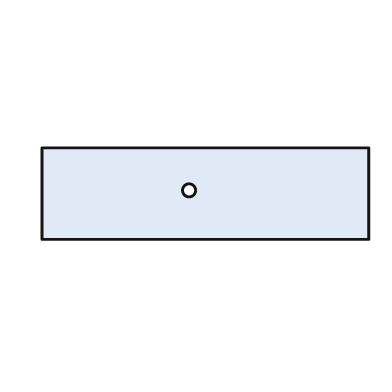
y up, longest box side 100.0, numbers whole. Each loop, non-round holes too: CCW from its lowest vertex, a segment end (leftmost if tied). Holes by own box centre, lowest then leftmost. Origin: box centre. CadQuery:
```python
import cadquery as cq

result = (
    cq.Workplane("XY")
    .moveTo(-50.0, -14.0)
    .lineTo(50.0, -14.0)
    .lineTo(50.0, 14.0)
    .lineTo(-50.0, 14.0)
    .close()
    .moveTo(-5.0, 1.0)
    .circle(2.0)
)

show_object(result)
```